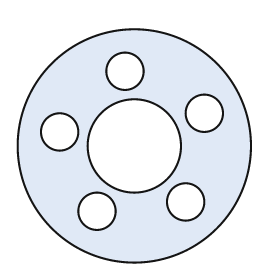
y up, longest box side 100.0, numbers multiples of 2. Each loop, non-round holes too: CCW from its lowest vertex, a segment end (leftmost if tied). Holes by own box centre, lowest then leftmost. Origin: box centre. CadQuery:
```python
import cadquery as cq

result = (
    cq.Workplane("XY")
    .moveTo(0.0, 0.0)
    .circle(50.0)
    .moveTo(-16.0, -28.0)
    .circle(8.0)
    .moveTo(22.0, -24.0)
    .circle(8.0)
    .moveTo(0.0, 0.0)
    .circle(20.0)
    .moveTo(-32.0, 6.0)
    .circle(8.0)
    .moveTo(30.0, 14.0)
    .circle(8.0)
    .moveTo(-4.0, 32.0)
    .circle(8.0)
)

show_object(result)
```